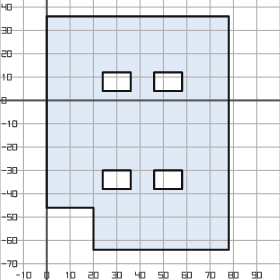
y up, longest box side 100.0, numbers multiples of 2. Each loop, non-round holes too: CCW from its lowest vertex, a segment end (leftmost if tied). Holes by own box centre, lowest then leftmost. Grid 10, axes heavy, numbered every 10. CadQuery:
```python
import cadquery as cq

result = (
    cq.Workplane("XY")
    .moveTo(20.0, -64.0)
    .lineTo(78.0, -64.0)
    .lineTo(78.0, 36.0)
    .lineTo(0.0, 36.0)
    .lineTo(0.0, -46.0)
    .lineTo(20.0, -46.0)
    .close()
    .moveTo(24.0, -38.0)
    .lineTo(36.0, -38.0)
    .lineTo(36.0, -30.0)
    .lineTo(24.0, -30.0)
    .close()
    .moveTo(46.0, -38.0)
    .lineTo(58.0, -38.0)
    .lineTo(58.0, -30.0)
    .lineTo(46.0, -30.0)
    .close()
    .moveTo(24.0, 4.0)
    .lineTo(36.0, 4.0)
    .lineTo(36.0, 12.0)
    .lineTo(24.0, 12.0)
    .close()
    .moveTo(46.0, 4.0)
    .lineTo(58.0, 4.0)
    .lineTo(58.0, 12.0)
    .lineTo(46.0, 12.0)
    .close()
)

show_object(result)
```